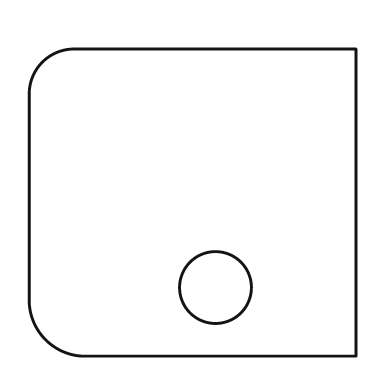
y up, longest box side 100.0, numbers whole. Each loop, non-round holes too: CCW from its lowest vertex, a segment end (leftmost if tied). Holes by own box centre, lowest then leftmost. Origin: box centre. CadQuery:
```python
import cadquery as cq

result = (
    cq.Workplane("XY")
    .moveTo(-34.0, -47.0)
    .lineTo(50.0, -47.0)
    .lineTo(50.0, 47.0)
    .lineTo(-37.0, 47.0)
    .threePointArc((-46.0, 43.0), (-50.0, 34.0))
    .lineTo(-50.0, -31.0)
    .threePointArc((-45.0, -42.0), (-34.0, -47.0))
    .close()
    .moveTo(7.0, -26.0)
    .circle(11.0)
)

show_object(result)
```